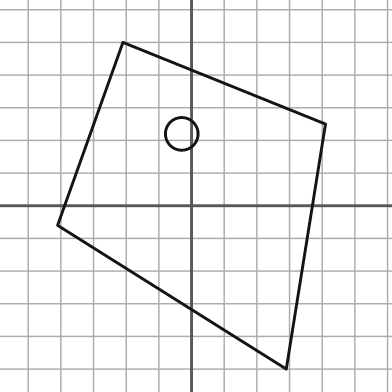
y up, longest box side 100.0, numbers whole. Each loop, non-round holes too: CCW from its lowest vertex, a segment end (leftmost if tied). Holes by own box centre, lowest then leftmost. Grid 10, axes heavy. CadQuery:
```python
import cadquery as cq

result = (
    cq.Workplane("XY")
    .moveTo(29.0, -50.0)
    .lineTo(41.0, 25.0)
    .lineTo(-21.0, 50.0)
    .lineTo(-41.0, -6.0)
    .close()
    .moveTo(-3.0, 22.0)
    .circle(5.0)
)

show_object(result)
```